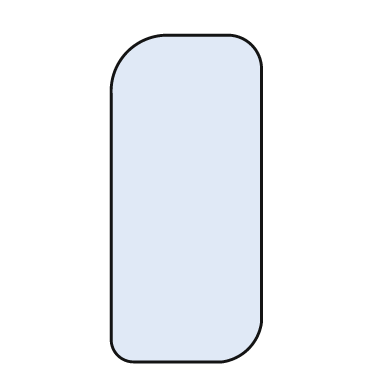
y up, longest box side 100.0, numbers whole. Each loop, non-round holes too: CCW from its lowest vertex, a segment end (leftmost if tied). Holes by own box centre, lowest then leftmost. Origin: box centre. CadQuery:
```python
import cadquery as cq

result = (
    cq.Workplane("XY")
    .moveTo(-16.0, -50.0)
    .lineTo(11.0, -50.0)
    .threePointArc((19.0, -46.0), (23.0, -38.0))
    .lineTo(23.0, 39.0)
    .threePointArc((20.0, 47.0), (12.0, 50.0))
    .lineTo(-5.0, 50.0)
    .threePointArc((-18.0, 45.0), (-23.0, 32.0))
    .lineTo(-23.0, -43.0)
    .threePointArc((-21.0, -48.0), (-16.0, -50.0))
    .close()
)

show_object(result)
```